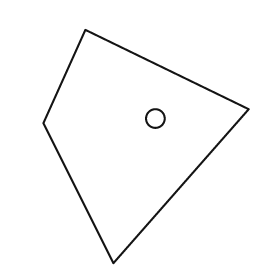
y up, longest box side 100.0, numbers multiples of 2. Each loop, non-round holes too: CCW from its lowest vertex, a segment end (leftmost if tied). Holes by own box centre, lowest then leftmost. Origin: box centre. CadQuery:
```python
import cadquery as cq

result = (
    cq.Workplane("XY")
    .moveTo(-14.0, -50.0)
    .lineTo(44.0, 16.0)
    .lineTo(-26.0, 50.0)
    .lineTo(-44.0, 10.0)
    .close()
    .moveTo(4.0, 12.0)
    .circle(4.0)
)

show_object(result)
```